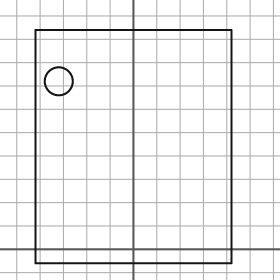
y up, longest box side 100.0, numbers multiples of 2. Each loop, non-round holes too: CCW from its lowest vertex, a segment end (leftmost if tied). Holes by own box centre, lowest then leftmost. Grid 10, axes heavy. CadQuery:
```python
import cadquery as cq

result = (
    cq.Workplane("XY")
    .moveTo(-42.0, -6.0)
    .lineTo(42.0, -6.0)
    .lineTo(42.0, 94.0)
    .lineTo(-42.0, 94.0)
    .close()
    .moveTo(-32.0, 72.0)
    .circle(6.0)
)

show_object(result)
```